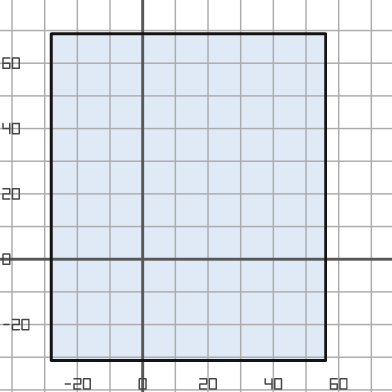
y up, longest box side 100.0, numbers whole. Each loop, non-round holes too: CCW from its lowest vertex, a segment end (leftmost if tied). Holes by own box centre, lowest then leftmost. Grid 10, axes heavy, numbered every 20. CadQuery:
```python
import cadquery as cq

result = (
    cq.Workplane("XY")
    .moveTo(-28.0, -31.0)
    .lineTo(56.0, -31.0)
    .lineTo(56.0, 69.0)
    .lineTo(-28.0, 69.0)
    .close()
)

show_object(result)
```